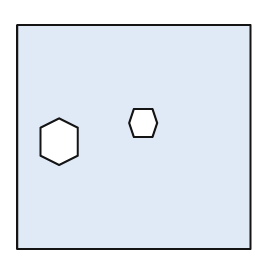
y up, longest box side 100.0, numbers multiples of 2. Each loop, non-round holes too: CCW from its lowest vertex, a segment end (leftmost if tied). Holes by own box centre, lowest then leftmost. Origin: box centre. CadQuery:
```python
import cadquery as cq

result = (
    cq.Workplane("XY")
    .moveTo(-50.0, -48.0)
    .lineTo(50.0, -48.0)
    .lineTo(50.0, 48.0)
    .lineTo(-50.0, 48.0)
    .close()
    .moveTo(-32.0, -12.0)
    .lineTo(-24.0, -8.0)
    .lineTo(-24.0, 4.0)
    .lineTo(-32.0, 8.0)
    .lineTo(-40.0, 4.0)
    .lineTo(-40.0, -8.0)
    .close()
    .moveTo(0.0, 0.0)
    .lineTo(8.0, 0.0)
    .lineTo(10.0, 6.0)
    .lineTo(8.0, 12.0)
    .lineTo(0.0, 12.0)
    .lineTo(-2.0, 6.0)
    .close()
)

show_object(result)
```